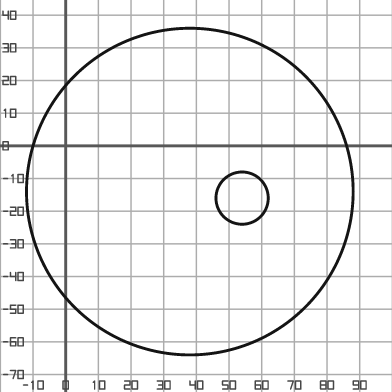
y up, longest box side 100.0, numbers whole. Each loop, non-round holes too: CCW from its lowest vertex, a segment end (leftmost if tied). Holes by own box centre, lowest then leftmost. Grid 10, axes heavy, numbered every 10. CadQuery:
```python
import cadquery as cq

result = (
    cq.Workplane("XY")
    .moveTo(38.0, -14.0)
    .circle(50.0)
    .moveTo(54.0, -16.0)
    .circle(8.0)
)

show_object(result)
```